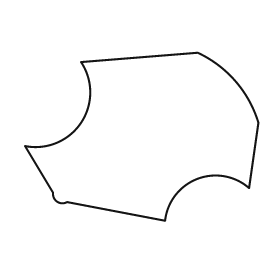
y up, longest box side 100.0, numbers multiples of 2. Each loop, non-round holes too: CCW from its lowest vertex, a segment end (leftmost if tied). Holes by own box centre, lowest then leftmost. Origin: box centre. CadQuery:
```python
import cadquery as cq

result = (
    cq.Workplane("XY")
    .moveTo(10.0, -36.0)
    .threePointArc((24.0, -18.0), (46.0, -22.0))
    .lineTo(50.0, 6.0)
    .threePointArc((40.0, 24.0), (24.0, 36.0))
    .lineTo(-26.0, 32.0)
    .threePointArc((-26.0, 6.0), (-50.0, -4.0))
    .lineTo(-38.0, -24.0)
    .threePointArc((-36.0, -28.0), (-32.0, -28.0))
    .close()
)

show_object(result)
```